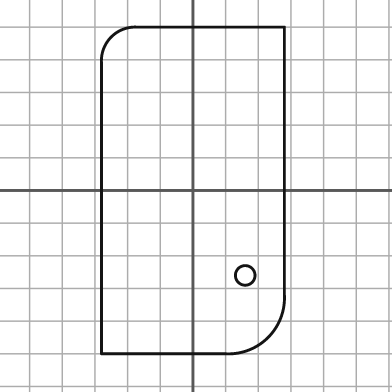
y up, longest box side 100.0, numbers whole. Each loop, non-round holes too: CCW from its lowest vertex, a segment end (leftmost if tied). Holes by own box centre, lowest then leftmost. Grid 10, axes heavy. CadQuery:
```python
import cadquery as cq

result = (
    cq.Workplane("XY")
    .moveTo(-28.0, -50.0)
    .lineTo(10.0, -50.0)
    .threePointArc((23.0, -45.0), (28.0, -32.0))
    .lineTo(28.0, 50.0)
    .lineTo(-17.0, 50.0)
    .threePointArc((-25.0, 47.0), (-28.0, 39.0))
    .close()
    .moveTo(16.0, -26.0)
    .circle(3.0)
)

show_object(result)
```